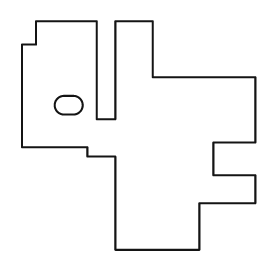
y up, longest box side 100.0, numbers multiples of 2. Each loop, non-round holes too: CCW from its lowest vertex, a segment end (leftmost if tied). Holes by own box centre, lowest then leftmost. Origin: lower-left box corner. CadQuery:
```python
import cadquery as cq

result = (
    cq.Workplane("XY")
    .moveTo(40.0, 0.0)
    .lineTo(76.0, 0.0)
    .lineTo(76.0, 20.0)
    .lineTo(100.0, 20.0)
    .lineTo(100.0, 32.0)
    .lineTo(82.0, 32.0)
    .lineTo(82.0, 46.0)
    .lineTo(100.0, 46.0)
    .lineTo(100.0, 74.0)
    .lineTo(56.0, 74.0)
    .lineTo(56.0, 98.0)
    .lineTo(40.0, 98.0)
    .lineTo(40.0, 56.0)
    .lineTo(32.0, 56.0)
    .lineTo(32.0, 98.0)
    .lineTo(6.0, 98.0)
    .lineTo(6.0, 88.0)
    .lineTo(0.0, 88.0)
    .lineTo(0.0, 44.0)
    .lineTo(28.0, 44.0)
    .lineTo(28.0, 40.0)
    .lineTo(40.0, 40.0)
    .close()
    .moveTo(18.0, 58.0)
    .lineTo(22.0, 58.0)
    .threePointArc((26.0, 62.0), (22.0, 66.0))
    .lineTo(18.0, 66.0)
    .threePointArc((14.0, 62.0), (18.0, 58.0))
    .close()
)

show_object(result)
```